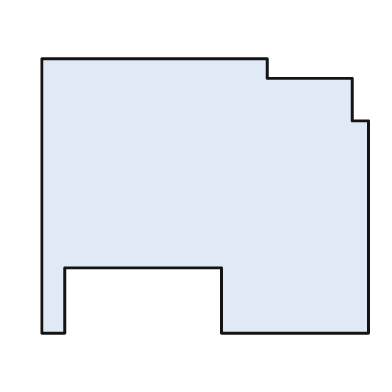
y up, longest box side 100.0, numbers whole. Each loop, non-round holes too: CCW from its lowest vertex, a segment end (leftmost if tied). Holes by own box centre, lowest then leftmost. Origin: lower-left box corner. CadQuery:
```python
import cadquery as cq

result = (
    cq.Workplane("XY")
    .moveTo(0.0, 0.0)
    .lineTo(7.0, 0.0)
    .lineTo(7.0, 20.0)
    .lineTo(55.0, 20.0)
    .lineTo(55.0, 0.0)
    .lineTo(100.0, 0.0)
    .lineTo(100.0, 65.0)
    .lineTo(95.0, 65.0)
    .lineTo(95.0, 78.0)
    .lineTo(69.0, 78.0)
    .lineTo(69.0, 84.0)
    .lineTo(0.0, 84.0)
    .close()
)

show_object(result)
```